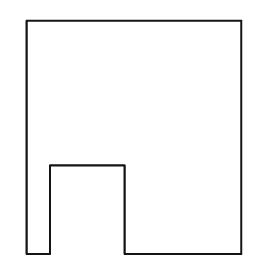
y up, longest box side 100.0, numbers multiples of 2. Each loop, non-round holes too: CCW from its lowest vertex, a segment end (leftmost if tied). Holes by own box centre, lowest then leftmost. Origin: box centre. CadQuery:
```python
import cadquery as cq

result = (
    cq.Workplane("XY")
    .moveTo(-46.0, -50.0)
    .lineTo(-36.0, -50.0)
    .lineTo(-36.0, -12.0)
    .lineTo(-4.0, -12.0)
    .lineTo(-4.0, -50.0)
    .lineTo(46.0, -50.0)
    .lineTo(46.0, 50.0)
    .lineTo(-46.0, 50.0)
    .close()
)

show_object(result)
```